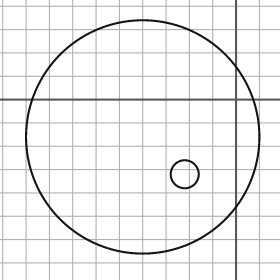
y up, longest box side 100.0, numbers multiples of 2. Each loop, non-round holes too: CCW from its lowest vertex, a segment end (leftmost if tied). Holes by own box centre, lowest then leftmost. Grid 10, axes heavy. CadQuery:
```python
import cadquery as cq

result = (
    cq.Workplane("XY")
    .moveTo(-40.0, -16.0)
    .circle(50.0)
    .moveTo(-22.0, -32.0)
    .circle(6.0)
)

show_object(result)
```